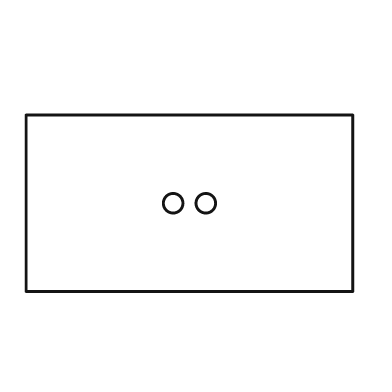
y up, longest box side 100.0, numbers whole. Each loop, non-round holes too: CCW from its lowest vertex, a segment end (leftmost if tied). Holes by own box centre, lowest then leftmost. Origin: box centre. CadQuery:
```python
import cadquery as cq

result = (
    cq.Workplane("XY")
    .moveTo(-50.0, -27.0)
    .lineTo(50.0, -27.0)
    .lineTo(50.0, 27.0)
    .lineTo(-50.0, 27.0)
    .close()
    .moveTo(-5.0, 0.0)
    .circle(3.0)
    .moveTo(5.0, 0.0)
    .circle(3.0)
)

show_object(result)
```